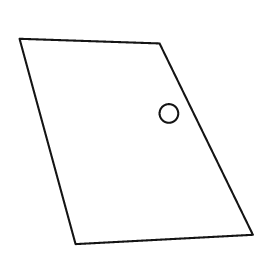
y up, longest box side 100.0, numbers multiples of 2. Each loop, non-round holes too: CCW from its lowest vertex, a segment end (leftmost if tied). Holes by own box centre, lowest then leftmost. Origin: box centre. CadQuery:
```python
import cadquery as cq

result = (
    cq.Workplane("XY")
    .moveTo(-26.0, -44.0)
    .lineTo(50.0, -40.0)
    .lineTo(10.0, 42.0)
    .lineTo(-50.0, 44.0)
    .close()
    .moveTo(14.0, 12.0)
    .circle(4.0)
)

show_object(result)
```